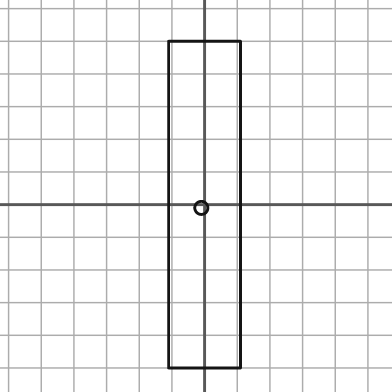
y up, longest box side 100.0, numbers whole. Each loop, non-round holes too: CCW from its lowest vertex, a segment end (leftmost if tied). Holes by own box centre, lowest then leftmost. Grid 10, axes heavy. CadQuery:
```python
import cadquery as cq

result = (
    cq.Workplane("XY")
    .moveTo(-11.0, -50.0)
    .lineTo(11.0, -50.0)
    .lineTo(11.0, 50.0)
    .lineTo(-11.0, 50.0)
    .close()
    .moveTo(-1.0, -1.0)
    .circle(2.0)
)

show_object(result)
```